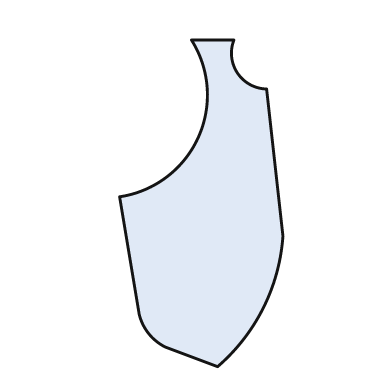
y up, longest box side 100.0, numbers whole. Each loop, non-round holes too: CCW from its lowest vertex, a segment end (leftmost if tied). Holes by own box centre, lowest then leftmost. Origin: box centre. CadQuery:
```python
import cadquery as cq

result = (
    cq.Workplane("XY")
    .moveTo(5.0, -50.0)
    .threePointArc((19.0, -32.0), (25.0, -10.0))
    .lineTo(20.0, 35.0)
    .threePointArc((11.0, 40.0), (10.0, 50.0))
    .lineTo(-3.0, 50.0)
    .threePointArc((-1.0, 20.0), (-25.0, 2.0))
    .lineTo(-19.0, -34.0)
    .threePointArc((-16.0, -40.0), (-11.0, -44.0))
    .close()
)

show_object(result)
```